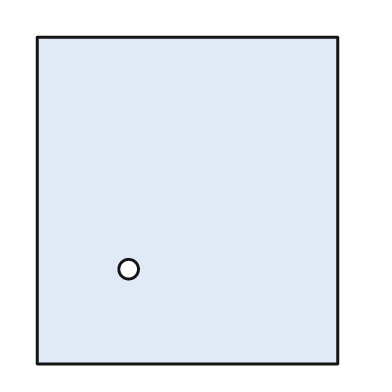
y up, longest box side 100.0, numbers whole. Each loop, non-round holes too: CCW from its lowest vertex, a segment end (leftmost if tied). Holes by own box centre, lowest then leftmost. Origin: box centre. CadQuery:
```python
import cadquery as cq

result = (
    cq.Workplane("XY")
    .moveTo(-46.0, -50.0)
    .lineTo(46.0, -50.0)
    .lineTo(46.0, 50.0)
    .lineTo(-46.0, 50.0)
    .close()
    .moveTo(-18.0, -21.0)
    .circle(3.0)
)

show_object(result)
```